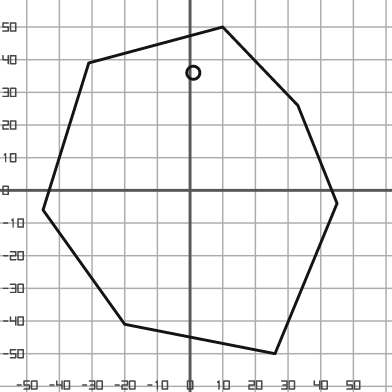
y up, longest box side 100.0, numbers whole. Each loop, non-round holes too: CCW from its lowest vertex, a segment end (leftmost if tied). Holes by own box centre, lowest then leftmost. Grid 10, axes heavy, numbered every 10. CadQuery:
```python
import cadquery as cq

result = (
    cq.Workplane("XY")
    .moveTo(26.0, -50.0)
    .lineTo(45.0, -4.0)
    .lineTo(33.0, 26.0)
    .lineTo(10.0, 50.0)
    .lineTo(-31.0, 39.0)
    .lineTo(-45.0, -6.0)
    .lineTo(-20.0, -41.0)
    .close()
    .moveTo(1.0, 36.0)
    .circle(2.0)
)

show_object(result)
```